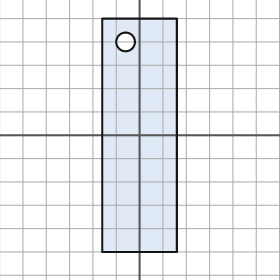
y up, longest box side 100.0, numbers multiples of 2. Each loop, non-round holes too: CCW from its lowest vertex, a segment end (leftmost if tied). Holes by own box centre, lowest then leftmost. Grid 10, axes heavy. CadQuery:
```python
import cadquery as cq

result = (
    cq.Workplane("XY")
    .moveTo(-16.0, -50.0)
    .lineTo(16.0, -50.0)
    .lineTo(16.0, 50.0)
    .lineTo(-16.0, 50.0)
    .close()
    .moveTo(-6.0, 40.0)
    .circle(4.0)
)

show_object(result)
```